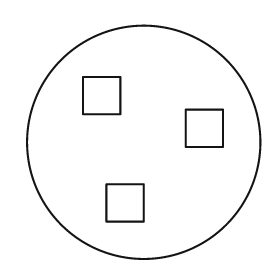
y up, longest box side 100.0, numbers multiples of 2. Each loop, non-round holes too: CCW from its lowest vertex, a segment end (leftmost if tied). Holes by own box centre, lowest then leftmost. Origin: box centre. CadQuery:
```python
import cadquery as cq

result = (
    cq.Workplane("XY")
    .moveTo(0.0, 0.0)
    .circle(50.0)
    .moveTo(-16.0, -34.0)
    .lineTo(0.0, -34.0)
    .lineTo(0.0, -18.0)
    .lineTo(-16.0, -18.0)
    .close()
    .moveTo(18.0, -2.0)
    .lineTo(34.0, -2.0)
    .lineTo(34.0, 14.0)
    .lineTo(18.0, 14.0)
    .close()
    .moveTo(-26.0, 12.0)
    .lineTo(-10.0, 12.0)
    .lineTo(-10.0, 28.0)
    .lineTo(-26.0, 28.0)
    .close()
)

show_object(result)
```